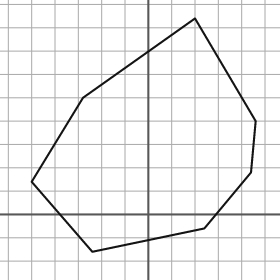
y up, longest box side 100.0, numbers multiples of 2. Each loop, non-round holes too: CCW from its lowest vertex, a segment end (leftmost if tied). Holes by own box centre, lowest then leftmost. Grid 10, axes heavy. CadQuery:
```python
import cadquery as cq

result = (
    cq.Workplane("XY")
    .moveTo(-24.0, -16.0)
    .lineTo(24.0, -6.0)
    .lineTo(44.0, 18.0)
    .lineTo(46.0, 40.0)
    .lineTo(20.0, 84.0)
    .lineTo(-28.0, 50.0)
    .lineTo(-50.0, 14.0)
    .close()
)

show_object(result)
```